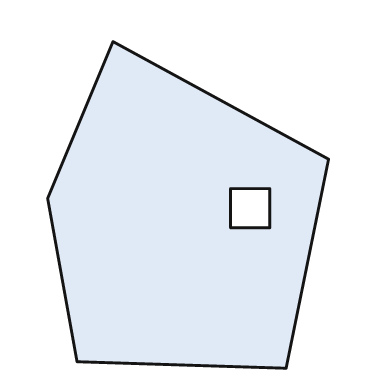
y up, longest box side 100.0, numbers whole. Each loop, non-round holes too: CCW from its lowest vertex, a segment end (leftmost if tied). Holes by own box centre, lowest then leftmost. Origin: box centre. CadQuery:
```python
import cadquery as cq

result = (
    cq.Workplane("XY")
    .moveTo(30.0, -50.0)
    .lineTo(43.0, 14.0)
    .lineTo(-23.0, 50.0)
    .lineTo(-43.0, 2.0)
    .lineTo(-34.0, -48.0)
    .close()
    .moveTo(13.0, -7.0)
    .lineTo(25.0, -7.0)
    .lineTo(25.0, 5.0)
    .lineTo(13.0, 5.0)
    .close()
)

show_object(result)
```